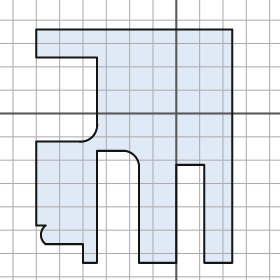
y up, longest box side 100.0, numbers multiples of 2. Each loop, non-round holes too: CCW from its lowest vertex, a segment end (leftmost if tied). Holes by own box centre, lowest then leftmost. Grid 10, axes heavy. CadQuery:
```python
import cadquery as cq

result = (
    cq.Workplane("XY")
    .moveTo(-40.0, -64.0)
    .lineTo(-34.0, -64.0)
    .lineTo(-34.0, -16.0)
    .lineTo(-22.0, -16.0)
    .threePointArc((-18.0, -18.0), (-16.0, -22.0))
    .lineTo(-16.0, -64.0)
    .lineTo(0.0, -64.0)
    .lineTo(0.0, -22.0)
    .lineTo(12.0, -22.0)
    .lineTo(12.0, -64.0)
    .lineTo(24.0, -64.0)
    .lineTo(24.0, 36.0)
    .lineTo(-60.0, 36.0)
    .lineTo(-60.0, 24.0)
    .lineTo(-34.0, 24.0)
    .lineTo(-34.0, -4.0)
    .threePointArc((-36.0, -10.0), (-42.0, -12.0))
    .lineTo(-60.0, -12.0)
    .lineTo(-60.0, -48.0)
    .lineTo(-56.0, -48.0)
    .threePointArc((-58.0, -52.0), (-56.0, -56.0))
    .lineTo(-40.0, -56.0)
    .close()
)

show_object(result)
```